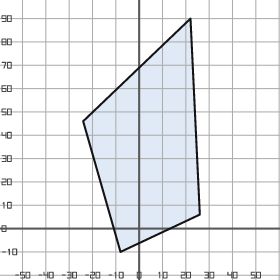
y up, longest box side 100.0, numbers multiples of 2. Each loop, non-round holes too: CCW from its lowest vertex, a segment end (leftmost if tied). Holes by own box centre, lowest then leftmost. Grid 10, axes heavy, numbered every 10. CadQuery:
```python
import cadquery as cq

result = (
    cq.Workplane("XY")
    .moveTo(-8.0, -10.0)
    .lineTo(26.0, 6.0)
    .lineTo(22.0, 90.0)
    .lineTo(-24.0, 46.0)
    .close()
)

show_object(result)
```